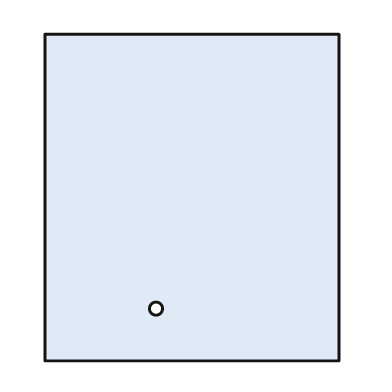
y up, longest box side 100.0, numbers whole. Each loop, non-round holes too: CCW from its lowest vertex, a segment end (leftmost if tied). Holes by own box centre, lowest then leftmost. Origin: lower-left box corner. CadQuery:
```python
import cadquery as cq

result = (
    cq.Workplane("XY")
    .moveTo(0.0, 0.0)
    .lineTo(90.0, 0.0)
    .lineTo(90.0, 100.0)
    .lineTo(0.0, 100.0)
    .close()
    .moveTo(34.0, 16.0)
    .circle(2.0)
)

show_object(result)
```